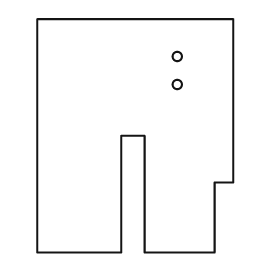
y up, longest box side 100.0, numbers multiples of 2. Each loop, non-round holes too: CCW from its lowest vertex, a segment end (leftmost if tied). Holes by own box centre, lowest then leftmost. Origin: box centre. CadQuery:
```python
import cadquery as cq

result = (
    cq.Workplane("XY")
    .moveTo(-42.0, -50.0)
    .lineTo(-6.0, -50.0)
    .lineTo(-6.0, 0.0)
    .lineTo(4.0, 0.0)
    .lineTo(4.0, -50.0)
    .lineTo(34.0, -50.0)
    .lineTo(34.0, -20.0)
    .lineTo(42.0, -20.0)
    .lineTo(42.0, 50.0)
    .lineTo(-42.0, 50.0)
    .close()
    .moveTo(18.0, 22.0)
    .circle(2.0)
    .moveTo(18.0, 34.0)
    .circle(2.0)
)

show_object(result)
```